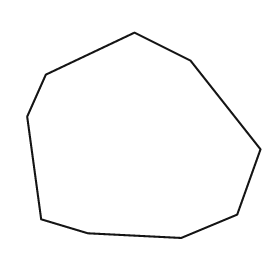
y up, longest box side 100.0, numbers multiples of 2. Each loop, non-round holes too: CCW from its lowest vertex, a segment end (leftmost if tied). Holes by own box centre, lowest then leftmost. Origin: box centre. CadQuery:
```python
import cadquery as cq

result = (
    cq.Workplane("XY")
    .moveTo(16.0, -44.0)
    .lineTo(40.0, -34.0)
    .lineTo(50.0, -6.0)
    .lineTo(20.0, 32.0)
    .lineTo(-4.0, 44.0)
    .lineTo(-42.0, 26.0)
    .lineTo(-50.0, 8.0)
    .lineTo(-44.0, -36.0)
    .lineTo(-24.0, -42.0)
    .close()
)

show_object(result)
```